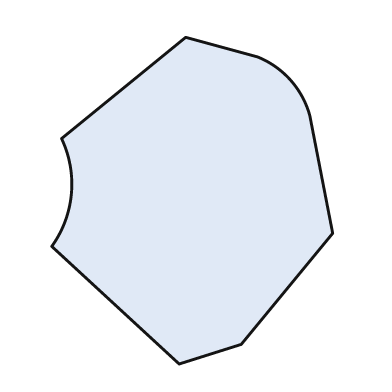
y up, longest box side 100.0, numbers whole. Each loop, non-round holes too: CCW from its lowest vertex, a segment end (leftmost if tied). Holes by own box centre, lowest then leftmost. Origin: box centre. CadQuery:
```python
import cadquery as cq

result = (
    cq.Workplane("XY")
    .moveTo(-4.0, -50.0)
    .lineTo(15.0, -44.0)
    .lineTo(43.0, -10.0)
    .lineTo(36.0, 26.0)
    .threePointArc((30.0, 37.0), (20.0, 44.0))
    .lineTo(-2.0, 50.0)
    .lineTo(-40.0, 19.0)
    .threePointArc((-37.0, 2.0), (-43.0, -14.0))
    .close()
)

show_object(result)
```